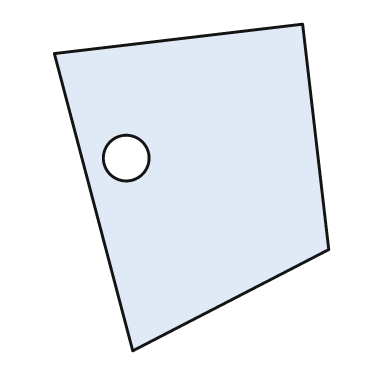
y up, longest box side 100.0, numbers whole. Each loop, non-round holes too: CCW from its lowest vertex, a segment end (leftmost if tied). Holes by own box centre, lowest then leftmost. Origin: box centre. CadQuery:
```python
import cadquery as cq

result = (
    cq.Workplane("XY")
    .moveTo(-18.0, -50.0)
    .lineTo(42.0, -19.0)
    .lineTo(34.0, 50.0)
    .lineTo(-42.0, 41.0)
    .close()
    .moveTo(-20.0, 9.0)
    .circle(7.0)
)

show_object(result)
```